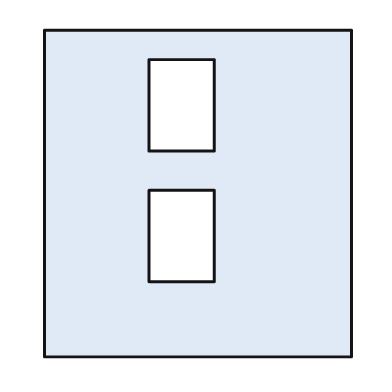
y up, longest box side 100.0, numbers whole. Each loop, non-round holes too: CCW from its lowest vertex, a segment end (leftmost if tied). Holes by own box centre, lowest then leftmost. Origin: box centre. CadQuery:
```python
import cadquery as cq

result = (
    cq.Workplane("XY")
    .moveTo(-47.0, -50.0)
    .lineTo(47.0, -50.0)
    .lineTo(47.0, 50.0)
    .lineTo(-47.0, 50.0)
    .close()
    .moveTo(-15.0, -27.0)
    .lineTo(5.0, -27.0)
    .lineTo(5.0, 1.0)
    .lineTo(-15.0, 1.0)
    .close()
    .moveTo(-15.0, 13.0)
    .lineTo(5.0, 13.0)
    .lineTo(5.0, 41.0)
    .lineTo(-15.0, 41.0)
    .close()
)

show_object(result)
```